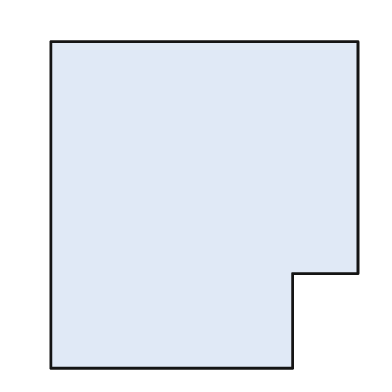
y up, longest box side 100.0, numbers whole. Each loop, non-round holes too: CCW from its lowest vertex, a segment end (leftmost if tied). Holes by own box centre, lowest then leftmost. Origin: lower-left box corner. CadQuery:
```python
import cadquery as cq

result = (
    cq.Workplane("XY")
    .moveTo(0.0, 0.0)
    .lineTo(74.0, 0.0)
    .lineTo(74.0, 29.0)
    .lineTo(94.0, 29.0)
    .lineTo(94.0, 100.0)
    .lineTo(0.0, 100.0)
    .close()
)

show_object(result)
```